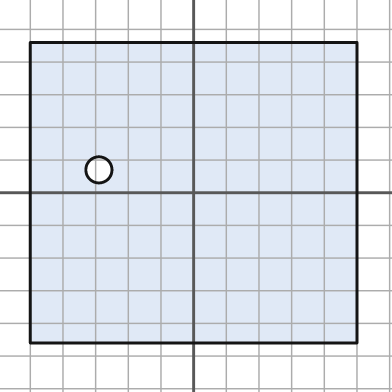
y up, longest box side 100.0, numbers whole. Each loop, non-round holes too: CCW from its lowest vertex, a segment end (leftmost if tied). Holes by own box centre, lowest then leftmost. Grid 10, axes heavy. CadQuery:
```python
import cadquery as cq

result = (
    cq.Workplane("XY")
    .moveTo(-50.0, -46.0)
    .lineTo(50.0, -46.0)
    .lineTo(50.0, 46.0)
    .lineTo(-50.0, 46.0)
    .close()
    .moveTo(-29.0, 7.0)
    .circle(4.0)
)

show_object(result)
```